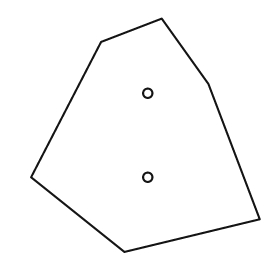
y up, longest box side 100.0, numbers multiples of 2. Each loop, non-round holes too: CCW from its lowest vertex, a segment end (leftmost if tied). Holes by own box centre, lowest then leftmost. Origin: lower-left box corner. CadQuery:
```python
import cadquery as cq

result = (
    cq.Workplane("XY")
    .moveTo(40.0, 0.0)
    .lineTo(98.0, 14.0)
    .lineTo(76.0, 72.0)
    .lineTo(56.0, 100.0)
    .lineTo(30.0, 90.0)
    .lineTo(0.0, 32.0)
    .close()
    .moveTo(50.0, 32.0)
    .circle(2.0)
    .moveTo(50.0, 68.0)
    .circle(2.0)
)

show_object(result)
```